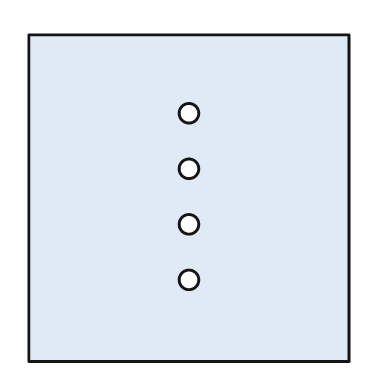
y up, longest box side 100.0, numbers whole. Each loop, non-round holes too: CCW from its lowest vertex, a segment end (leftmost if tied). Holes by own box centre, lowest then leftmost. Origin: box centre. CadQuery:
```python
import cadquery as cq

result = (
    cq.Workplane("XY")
    .moveTo(-49.0, -50.0)
    .lineTo(49.0, -50.0)
    .lineTo(49.0, 50.0)
    .lineTo(-49.0, 50.0)
    .close()
    .moveTo(0.0, -25.0)
    .circle(3.0)
    .moveTo(0.0, -8.0)
    .circle(3.0)
    .moveTo(0.0, 9.0)
    .circle(3.0)
    .moveTo(0.0, 26.0)
    .circle(3.0)
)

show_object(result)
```